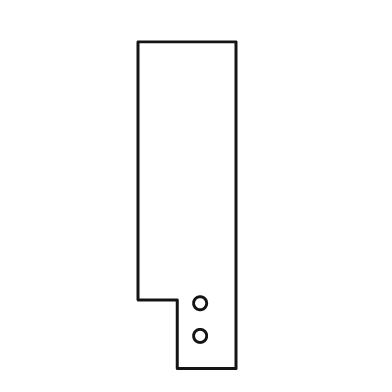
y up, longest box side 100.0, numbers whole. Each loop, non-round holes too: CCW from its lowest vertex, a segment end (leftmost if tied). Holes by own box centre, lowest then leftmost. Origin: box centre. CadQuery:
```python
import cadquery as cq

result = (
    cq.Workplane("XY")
    .moveTo(-3.0, -50.0)
    .lineTo(15.0, -50.0)
    .lineTo(15.0, 50.0)
    .lineTo(-15.0, 50.0)
    .lineTo(-15.0, -29.0)
    .lineTo(-3.0, -29.0)
    .close()
    .moveTo(4.0, -40.0)
    .circle(2.0)
    .moveTo(4.0, -30.0)
    .circle(2.0)
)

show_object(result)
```